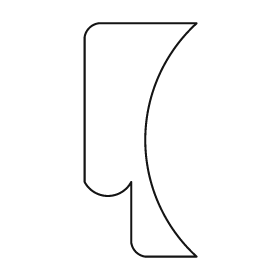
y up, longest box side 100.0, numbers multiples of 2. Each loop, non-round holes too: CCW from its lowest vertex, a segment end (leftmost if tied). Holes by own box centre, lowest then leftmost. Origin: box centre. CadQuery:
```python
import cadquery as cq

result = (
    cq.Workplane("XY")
    .moveTo(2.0, -50.0)
    .lineTo(24.0, -50.0)
    .threePointArc((2.0, 0.0), (24.0, 50.0))
    .lineTo(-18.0, 50.0)
    .threePointArc((-22.0, 48.0), (-24.0, 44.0))
    .lineTo(-24.0, -18.0)
    .threePointArc((-14.0, -24.0), (-4.0, -18.0))
    .lineTo(-4.0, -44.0)
    .threePointArc((-2.0, -48.0), (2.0, -50.0))
    .close()
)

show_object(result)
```